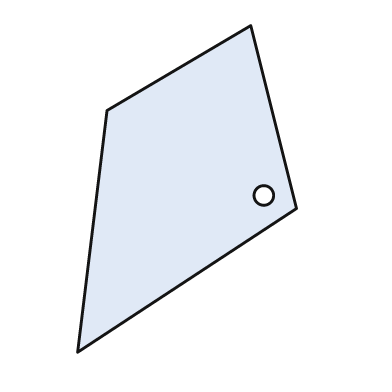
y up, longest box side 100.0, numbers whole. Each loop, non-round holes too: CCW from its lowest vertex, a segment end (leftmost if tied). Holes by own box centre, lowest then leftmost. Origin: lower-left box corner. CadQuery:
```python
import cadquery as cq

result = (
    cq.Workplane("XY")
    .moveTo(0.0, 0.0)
    .lineTo(67.0, 44.0)
    .lineTo(53.0, 100.0)
    .lineTo(9.0, 74.0)
    .close()
    .moveTo(57.0, 48.0)
    .circle(3.0)
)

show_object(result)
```